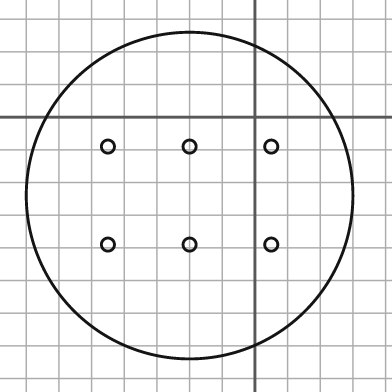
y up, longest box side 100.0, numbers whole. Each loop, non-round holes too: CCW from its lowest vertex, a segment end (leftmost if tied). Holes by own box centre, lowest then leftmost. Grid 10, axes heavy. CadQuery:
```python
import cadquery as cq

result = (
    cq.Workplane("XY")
    .moveTo(-20.0, -24.0)
    .circle(50.0)
    .moveTo(-45.0, -39.0)
    .circle(2.0)
    .moveTo(-20.0, -39.0)
    .circle(2.0)
    .moveTo(5.0, -39.0)
    .circle(2.0)
    .moveTo(-45.0, -9.0)
    .circle(2.0)
    .moveTo(-20.0, -9.0)
    .circle(2.0)
    .moveTo(5.0, -9.0)
    .circle(2.0)
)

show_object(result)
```